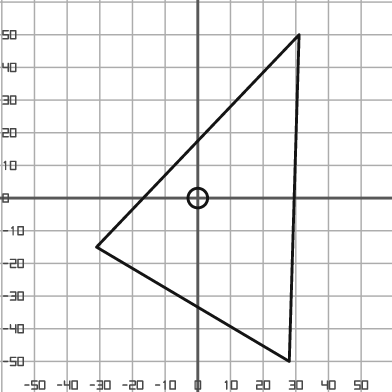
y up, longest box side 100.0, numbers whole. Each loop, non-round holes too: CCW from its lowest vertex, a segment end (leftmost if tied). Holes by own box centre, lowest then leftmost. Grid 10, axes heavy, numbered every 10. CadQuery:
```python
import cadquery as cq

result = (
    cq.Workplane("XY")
    .moveTo(28.0, -50.0)
    .lineTo(31.0, 50.0)
    .lineTo(-31.0, -15.0)
    .close()
    .moveTo(0.0, 0.0)
    .circle(3.0)
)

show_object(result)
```